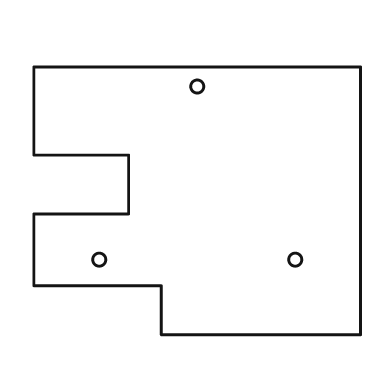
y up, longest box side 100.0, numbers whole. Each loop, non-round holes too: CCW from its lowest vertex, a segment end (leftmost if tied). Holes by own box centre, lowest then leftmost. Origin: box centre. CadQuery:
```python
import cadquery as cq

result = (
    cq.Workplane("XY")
    .moveTo(-11.0, -41.0)
    .lineTo(50.0, -41.0)
    .lineTo(50.0, 41.0)
    .lineTo(-50.0, 41.0)
    .lineTo(-50.0, 14.0)
    .lineTo(-21.0, 14.0)
    .lineTo(-21.0, -4.0)
    .lineTo(-50.0, -4.0)
    .lineTo(-50.0, -26.0)
    .lineTo(-11.0, -26.0)
    .close()
    .moveTo(-30.0, -18.0)
    .circle(2.0)
    .moveTo(30.0, -18.0)
    .circle(2.0)
    .moveTo(0.0, 35.0)
    .circle(2.0)
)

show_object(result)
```